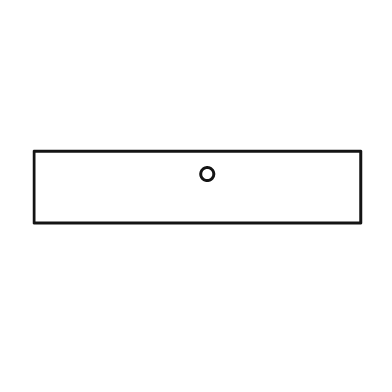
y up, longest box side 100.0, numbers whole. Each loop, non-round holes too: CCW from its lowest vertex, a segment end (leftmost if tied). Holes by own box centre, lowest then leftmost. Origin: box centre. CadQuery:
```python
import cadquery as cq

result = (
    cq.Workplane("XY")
    .moveTo(-50.0, -11.0)
    .lineTo(50.0, -11.0)
    .lineTo(50.0, 11.0)
    .lineTo(-50.0, 11.0)
    .close()
    .moveTo(3.0, 4.0)
    .circle(2.0)
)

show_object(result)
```